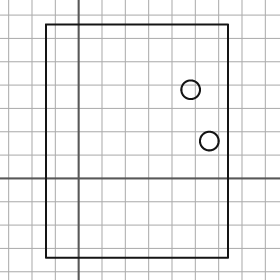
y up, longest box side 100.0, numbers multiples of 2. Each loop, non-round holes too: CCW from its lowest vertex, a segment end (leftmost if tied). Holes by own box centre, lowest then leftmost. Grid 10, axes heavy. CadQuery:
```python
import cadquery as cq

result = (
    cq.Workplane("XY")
    .moveTo(-14.0, -34.0)
    .lineTo(64.0, -34.0)
    .lineTo(64.0, 66.0)
    .lineTo(-14.0, 66.0)
    .close()
    .moveTo(56.0, 16.0)
    .circle(4.0)
    .moveTo(48.0, 38.0)
    .circle(4.0)
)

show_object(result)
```